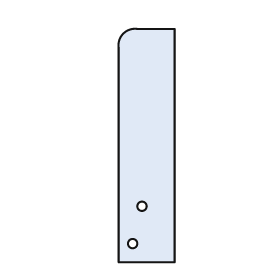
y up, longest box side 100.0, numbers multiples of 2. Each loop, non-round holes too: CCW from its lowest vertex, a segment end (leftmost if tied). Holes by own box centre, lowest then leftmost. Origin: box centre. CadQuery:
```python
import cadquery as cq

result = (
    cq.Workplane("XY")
    .moveTo(-12.0, -50.0)
    .lineTo(12.0, -50.0)
    .lineTo(12.0, 50.0)
    .lineTo(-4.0, 50.0)
    .threePointArc((-10.0, 48.0), (-12.0, 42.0))
    .close()
    .moveTo(-6.0, -42.0)
    .circle(2.0)
    .moveTo(-2.0, -26.0)
    .circle(2.0)
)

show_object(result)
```